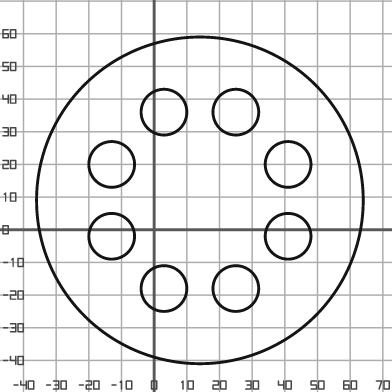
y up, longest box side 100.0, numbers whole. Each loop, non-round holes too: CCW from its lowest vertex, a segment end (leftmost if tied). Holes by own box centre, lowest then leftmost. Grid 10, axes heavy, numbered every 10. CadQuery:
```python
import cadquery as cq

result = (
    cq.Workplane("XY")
    .moveTo(14.0, 9.0)
    .circle(50.0)
    .moveTo(3.0, -18.0)
    .circle(7.0)
    .moveTo(25.0, -18.0)
    .circle(7.0)
    .moveTo(-13.0, -2.0)
    .circle(7.0)
    .moveTo(41.0, -2.0)
    .circle(7.0)
    .moveTo(-13.0, 20.0)
    .circle(7.0)
    .moveTo(41.0, 20.0)
    .circle(7.0)
    .moveTo(3.0, 36.0)
    .circle(7.0)
    .moveTo(25.0, 36.0)
    .circle(7.0)
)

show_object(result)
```